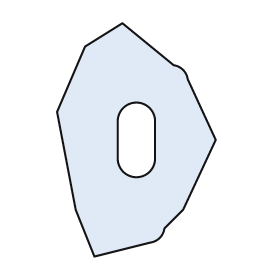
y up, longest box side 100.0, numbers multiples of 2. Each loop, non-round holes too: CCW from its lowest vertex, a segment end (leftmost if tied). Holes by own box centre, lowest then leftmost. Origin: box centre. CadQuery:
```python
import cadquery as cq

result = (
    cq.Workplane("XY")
    .moveTo(-18.0, -50.0)
    .lineTo(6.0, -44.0)
    .threePointArc((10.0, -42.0), (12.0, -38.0))
    .lineTo(20.0, -30.0)
    .lineTo(34.0, 0.0)
    .lineTo(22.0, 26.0)
    .threePointArc((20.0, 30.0), (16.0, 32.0))
    .lineTo(-6.0, 50.0)
    .lineTo(-22.0, 40.0)
    .lineTo(-34.0, 12.0)
    .lineTo(-26.0, -30.0)
    .close()
    .moveTo(-8.0, -8.0)
    .threePointArc((0.0, -16.0), (8.0, -8.0))
    .lineTo(8.0, 8.0)
    .threePointArc((0.0, 16.0), (-8.0, 8.0))
    .close()
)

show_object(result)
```